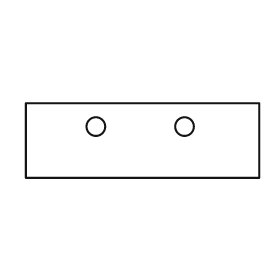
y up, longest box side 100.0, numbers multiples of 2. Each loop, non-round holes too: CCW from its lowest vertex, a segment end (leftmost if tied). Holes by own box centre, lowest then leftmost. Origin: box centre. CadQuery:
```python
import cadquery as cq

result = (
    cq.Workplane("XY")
    .moveTo(-50.0, -16.0)
    .lineTo(50.0, -16.0)
    .lineTo(50.0, 16.0)
    .lineTo(-50.0, 16.0)
    .close()
    .moveTo(-20.0, 6.0)
    .circle(4.0)
    .moveTo(18.0, 6.0)
    .circle(4.0)
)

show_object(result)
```